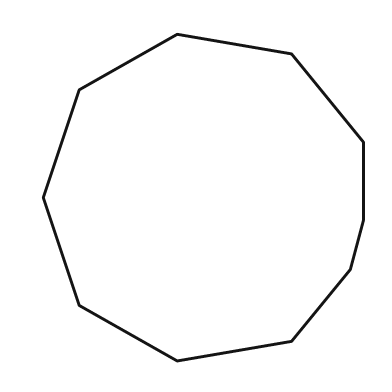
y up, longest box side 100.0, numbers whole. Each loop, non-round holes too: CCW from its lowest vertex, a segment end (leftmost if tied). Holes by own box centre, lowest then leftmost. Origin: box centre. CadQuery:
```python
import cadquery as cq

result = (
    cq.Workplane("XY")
    .moveTo(-8.0, -50.0)
    .lineTo(27.0, -44.0)
    .lineTo(45.0, -22.0)
    .lineTo(49.0, -7.0)
    .lineTo(49.0, 17.0)
    .lineTo(27.0, 44.0)
    .lineTo(-8.0, 50.0)
    .lineTo(-38.0, 33.0)
    .lineTo(-49.0, 0.0)
    .lineTo(-38.0, -33.0)
    .close()
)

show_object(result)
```